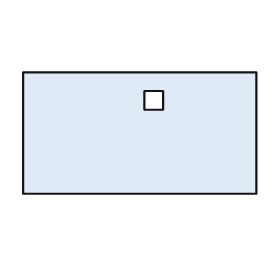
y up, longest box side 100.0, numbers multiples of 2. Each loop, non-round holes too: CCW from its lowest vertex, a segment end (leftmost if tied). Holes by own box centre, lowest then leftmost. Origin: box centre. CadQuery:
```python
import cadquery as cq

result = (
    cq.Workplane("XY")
    .moveTo(-50.0, -26.0)
    .lineTo(50.0, -26.0)
    .lineTo(50.0, 26.0)
    .lineTo(-50.0, 26.0)
    .close()
    .moveTo(2.0, 10.0)
    .lineTo(10.0, 10.0)
    .lineTo(10.0, 18.0)
    .lineTo(2.0, 18.0)
    .close()
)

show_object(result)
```